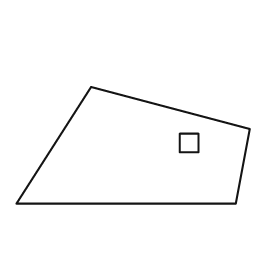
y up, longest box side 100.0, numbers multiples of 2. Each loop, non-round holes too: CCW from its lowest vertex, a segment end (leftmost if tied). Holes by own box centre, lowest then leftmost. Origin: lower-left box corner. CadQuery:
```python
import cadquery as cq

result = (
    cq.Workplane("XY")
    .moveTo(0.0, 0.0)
    .lineTo(94.0, 0.0)
    .lineTo(100.0, 32.0)
    .lineTo(32.0, 50.0)
    .close()
    .moveTo(70.0, 22.0)
    .lineTo(78.0, 22.0)
    .lineTo(78.0, 30.0)
    .lineTo(70.0, 30.0)
    .close()
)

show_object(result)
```